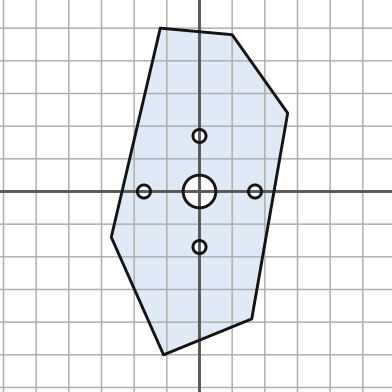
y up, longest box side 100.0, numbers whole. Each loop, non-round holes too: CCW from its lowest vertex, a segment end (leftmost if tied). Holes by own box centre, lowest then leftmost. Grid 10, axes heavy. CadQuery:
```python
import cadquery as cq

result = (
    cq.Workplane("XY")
    .moveTo(-11.0, -50.0)
    .lineTo(16.0, -39.0)
    .lineTo(27.0, 24.0)
    .lineTo(10.0, 48.0)
    .lineTo(-12.0, 50.0)
    .lineTo(-27.0, -14.0)
    .close()
    .moveTo(0.0, -17.0)
    .circle(2.0)
    .moveTo(-17.0, 0.0)
    .circle(2.0)
    .moveTo(0.0, 0.0)
    .circle(5.0)
    .moveTo(17.0, 0.0)
    .circle(2.0)
    .moveTo(0.0, 17.0)
    .circle(2.0)
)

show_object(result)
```